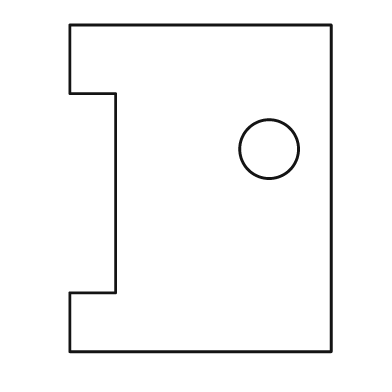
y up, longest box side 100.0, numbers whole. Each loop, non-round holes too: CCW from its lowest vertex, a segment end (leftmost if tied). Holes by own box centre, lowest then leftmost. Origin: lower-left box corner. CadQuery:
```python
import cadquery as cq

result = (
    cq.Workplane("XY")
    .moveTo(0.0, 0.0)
    .lineTo(80.0, 0.0)
    .lineTo(80.0, 100.0)
    .lineTo(0.0, 100.0)
    .lineTo(0.0, 79.0)
    .lineTo(14.0, 79.0)
    .lineTo(14.0, 18.0)
    .lineTo(0.0, 18.0)
    .close()
    .moveTo(61.0, 62.0)
    .circle(9.0)
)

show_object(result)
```